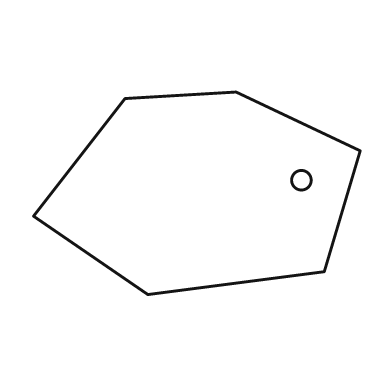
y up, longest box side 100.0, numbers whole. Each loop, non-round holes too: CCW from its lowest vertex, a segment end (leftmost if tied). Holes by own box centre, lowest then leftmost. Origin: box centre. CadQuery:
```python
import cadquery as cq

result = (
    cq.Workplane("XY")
    .moveTo(-15.0, -31.0)
    .lineTo(39.0, -24.0)
    .lineTo(50.0, 13.0)
    .lineTo(12.0, 31.0)
    .lineTo(-22.0, 29.0)
    .lineTo(-50.0, -7.0)
    .close()
    .moveTo(32.0, 4.0)
    .circle(3.0)
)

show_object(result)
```